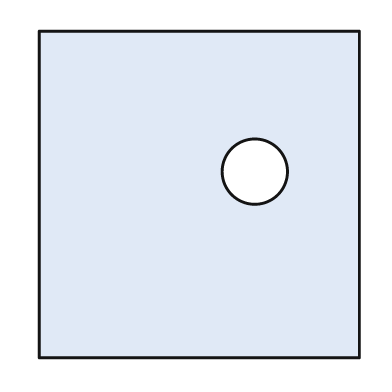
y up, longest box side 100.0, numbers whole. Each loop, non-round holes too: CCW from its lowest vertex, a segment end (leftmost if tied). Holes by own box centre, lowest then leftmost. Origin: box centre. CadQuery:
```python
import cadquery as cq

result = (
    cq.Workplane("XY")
    .moveTo(-49.0, -50.0)
    .lineTo(49.0, -50.0)
    .lineTo(49.0, 50.0)
    .lineTo(-49.0, 50.0)
    .close()
    .moveTo(17.0, 7.0)
    .circle(10.0)
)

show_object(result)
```